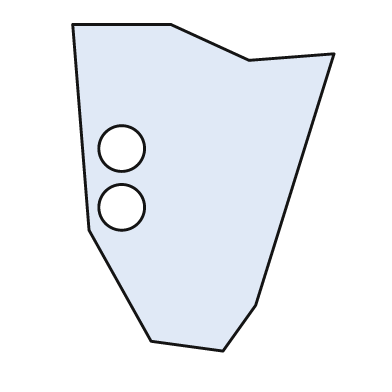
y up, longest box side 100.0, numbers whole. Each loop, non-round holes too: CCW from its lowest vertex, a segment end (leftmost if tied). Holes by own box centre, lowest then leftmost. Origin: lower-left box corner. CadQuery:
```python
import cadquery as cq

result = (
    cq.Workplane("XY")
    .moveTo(46.0, 0.0)
    .lineTo(56.0, 14.0)
    .lineTo(80.0, 91.0)
    .lineTo(54.0, 89.0)
    .lineTo(30.0, 100.0)
    .lineTo(0.0, 100.0)
    .lineTo(5.0, 37.0)
    .lineTo(24.0, 3.0)
    .close()
    .moveTo(15.0, 44.0)
    .circle(7.0)
    .moveTo(15.0, 62.0)
    .circle(7.0)
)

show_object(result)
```